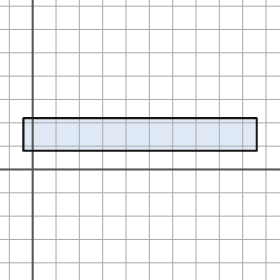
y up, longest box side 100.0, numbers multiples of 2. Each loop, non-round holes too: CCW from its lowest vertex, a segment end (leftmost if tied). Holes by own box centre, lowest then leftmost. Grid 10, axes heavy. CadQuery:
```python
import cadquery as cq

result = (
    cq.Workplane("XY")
    .moveTo(-4.0, 8.0)
    .lineTo(96.0, 8.0)
    .lineTo(96.0, 22.0)
    .lineTo(-4.0, 22.0)
    .close()
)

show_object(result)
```